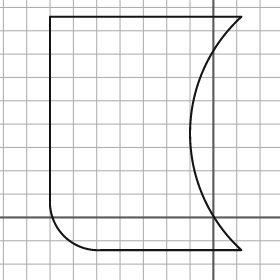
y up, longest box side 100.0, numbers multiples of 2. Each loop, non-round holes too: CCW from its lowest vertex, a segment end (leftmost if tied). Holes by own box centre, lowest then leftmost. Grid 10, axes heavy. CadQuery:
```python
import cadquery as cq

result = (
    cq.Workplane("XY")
    .moveTo(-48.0, -14.0)
    .lineTo(12.0, -14.0)
    .threePointArc((-10.0, 36.0), (12.0, 86.0))
    .lineTo(-70.0, 86.0)
    .lineTo(-70.0, 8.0)
    .threePointArc((-64.0, -8.0), (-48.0, -14.0))
    .close()
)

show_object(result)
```